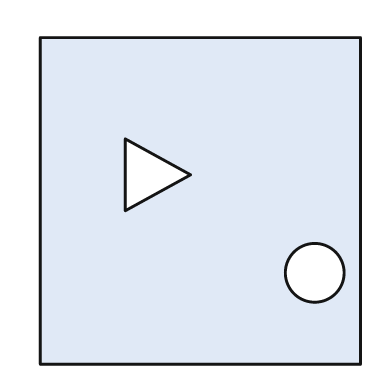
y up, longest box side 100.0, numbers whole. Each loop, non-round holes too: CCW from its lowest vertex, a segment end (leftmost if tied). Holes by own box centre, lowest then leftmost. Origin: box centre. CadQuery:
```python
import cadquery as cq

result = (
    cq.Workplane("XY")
    .moveTo(-49.0, -50.0)
    .lineTo(49.0, -50.0)
    .lineTo(49.0, 50.0)
    .lineTo(-49.0, 50.0)
    .close()
    .moveTo(35.0, -22.0)
    .circle(9.0)
    .moveTo(-23.0, -3.0)
    .lineTo(-3.0, 8.0)
    .lineTo(-23.0, 19.0)
    .close()
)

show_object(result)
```